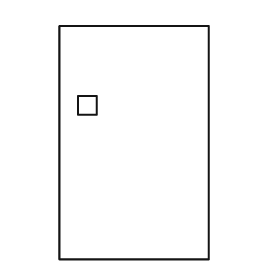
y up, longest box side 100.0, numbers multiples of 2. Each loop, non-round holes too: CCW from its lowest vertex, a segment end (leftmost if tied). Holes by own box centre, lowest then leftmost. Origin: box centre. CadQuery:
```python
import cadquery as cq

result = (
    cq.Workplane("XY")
    .moveTo(-32.0, -50.0)
    .lineTo(32.0, -50.0)
    .lineTo(32.0, 50.0)
    .lineTo(-32.0, 50.0)
    .close()
    .moveTo(-24.0, 12.0)
    .lineTo(-16.0, 12.0)
    .lineTo(-16.0, 20.0)
    .lineTo(-24.0, 20.0)
    .close()
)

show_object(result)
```